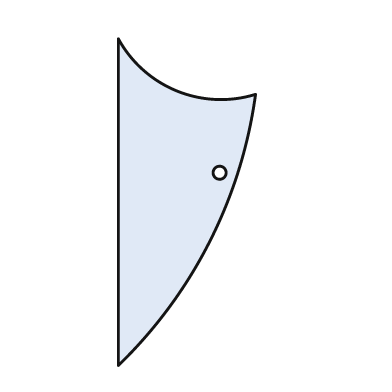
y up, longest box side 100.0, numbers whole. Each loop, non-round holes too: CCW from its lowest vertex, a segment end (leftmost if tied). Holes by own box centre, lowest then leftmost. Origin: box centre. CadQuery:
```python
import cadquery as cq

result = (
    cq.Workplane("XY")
    .moveTo(-21.0, -50.0)
    .threePointArc((7.0, -12.0), (21.0, 33.0))
    .threePointArc((-3.0, 34.0), (-21.0, 50.0))
    .close()
    .moveTo(10.0, 9.0)
    .circle(2.0)
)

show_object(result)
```